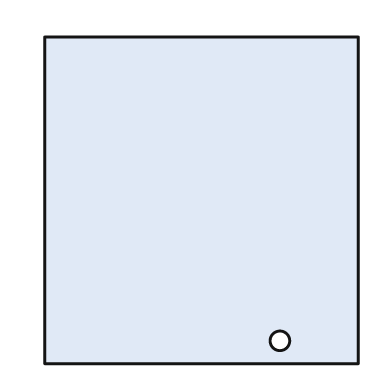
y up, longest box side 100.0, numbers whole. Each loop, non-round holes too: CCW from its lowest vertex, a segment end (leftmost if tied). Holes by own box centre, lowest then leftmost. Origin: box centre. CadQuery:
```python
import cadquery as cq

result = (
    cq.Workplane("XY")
    .moveTo(-48.0, -50.0)
    .lineTo(48.0, -50.0)
    .lineTo(48.0, 50.0)
    .lineTo(-48.0, 50.0)
    .close()
    .moveTo(24.0, -43.0)
    .circle(3.0)
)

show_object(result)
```